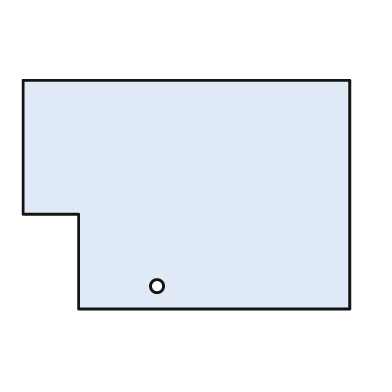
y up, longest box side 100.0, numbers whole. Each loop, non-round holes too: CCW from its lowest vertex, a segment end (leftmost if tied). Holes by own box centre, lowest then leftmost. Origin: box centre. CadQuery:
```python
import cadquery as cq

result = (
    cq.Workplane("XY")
    .moveTo(-33.0, -35.0)
    .lineTo(50.0, -35.0)
    .lineTo(50.0, 35.0)
    .lineTo(-50.0, 35.0)
    .lineTo(-50.0, -6.0)
    .lineTo(-33.0, -6.0)
    .close()
    .moveTo(-9.0, -28.0)
    .circle(2.0)
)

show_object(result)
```